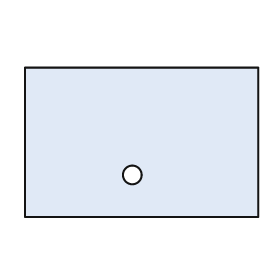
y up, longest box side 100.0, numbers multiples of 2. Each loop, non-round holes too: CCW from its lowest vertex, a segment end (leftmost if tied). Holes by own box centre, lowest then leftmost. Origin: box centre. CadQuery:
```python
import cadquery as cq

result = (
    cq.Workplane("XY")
    .moveTo(-50.0, -32.0)
    .lineTo(50.0, -32.0)
    .lineTo(50.0, 32.0)
    .lineTo(-50.0, 32.0)
    .close()
    .moveTo(-4.0, -14.0)
    .circle(4.0)
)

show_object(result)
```